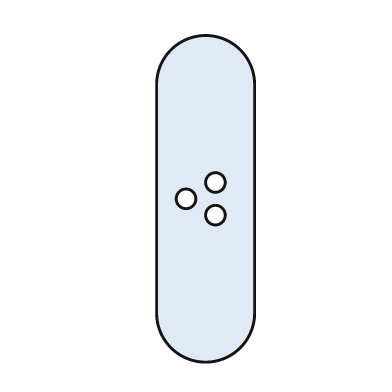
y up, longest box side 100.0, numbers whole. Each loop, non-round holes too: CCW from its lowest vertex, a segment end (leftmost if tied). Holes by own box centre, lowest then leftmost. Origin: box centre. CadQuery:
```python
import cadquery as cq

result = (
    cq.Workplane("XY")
    .moveTo(-15.0, -35.0)
    .threePointArc((0.0, -50.0), (15.0, -35.0))
    .lineTo(15.0, 35.0)
    .threePointArc((0.0, 50.0), (-15.0, 35.0))
    .close()
    .moveTo(3.0, -5.0)
    .circle(3.0)
    .moveTo(-6.0, 0.0)
    .circle(3.0)
    .moveTo(3.0, 5.0)
    .circle(3.0)
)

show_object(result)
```